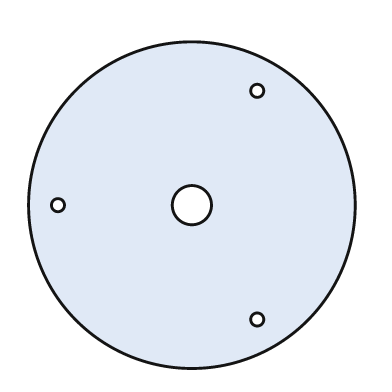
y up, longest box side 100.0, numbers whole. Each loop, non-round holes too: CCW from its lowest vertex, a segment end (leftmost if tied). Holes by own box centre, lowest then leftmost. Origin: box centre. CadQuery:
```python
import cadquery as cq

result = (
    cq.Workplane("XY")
    .moveTo(0.0, 0.0)
    .circle(50.0)
    .moveTo(20.0, -35.0)
    .circle(2.0)
    .moveTo(-41.0, 0.0)
    .circle(2.0)
    .moveTo(0.0, 0.0)
    .circle(6.0)
    .moveTo(20.0, 35.0)
    .circle(2.0)
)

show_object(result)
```